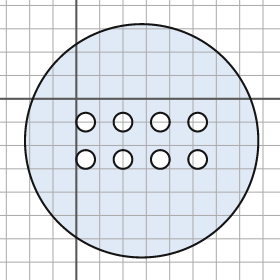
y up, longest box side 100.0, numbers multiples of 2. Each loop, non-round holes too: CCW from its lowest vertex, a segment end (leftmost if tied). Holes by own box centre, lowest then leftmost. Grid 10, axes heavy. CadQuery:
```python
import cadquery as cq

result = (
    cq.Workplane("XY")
    .moveTo(28.0, -18.0)
    .circle(50.0)
    .moveTo(4.0, -26.0)
    .circle(4.0)
    .moveTo(20.0, -26.0)
    .circle(4.0)
    .moveTo(36.0, -26.0)
    .circle(4.0)
    .moveTo(52.0, -26.0)
    .circle(4.0)
    .moveTo(4.0, -10.0)
    .circle(4.0)
    .moveTo(20.0, -10.0)
    .circle(4.0)
    .moveTo(36.0, -10.0)
    .circle(4.0)
    .moveTo(52.0, -10.0)
    .circle(4.0)
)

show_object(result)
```